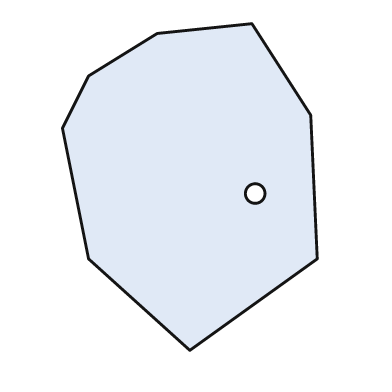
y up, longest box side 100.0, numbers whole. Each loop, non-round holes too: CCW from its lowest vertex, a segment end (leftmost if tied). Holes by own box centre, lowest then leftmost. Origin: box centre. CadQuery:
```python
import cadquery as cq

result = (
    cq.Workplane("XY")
    .moveTo(0.0, -50.0)
    .lineTo(39.0, -22.0)
    .lineTo(37.0, 22.0)
    .lineTo(19.0, 50.0)
    .lineTo(-10.0, 47.0)
    .lineTo(-31.0, 34.0)
    .lineTo(-39.0, 18.0)
    .lineTo(-31.0, -22.0)
    .close()
    .moveTo(20.0, -2.0)
    .circle(3.0)
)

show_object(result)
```